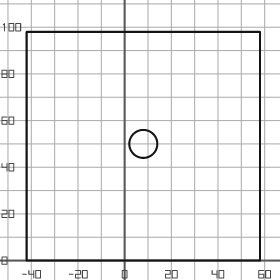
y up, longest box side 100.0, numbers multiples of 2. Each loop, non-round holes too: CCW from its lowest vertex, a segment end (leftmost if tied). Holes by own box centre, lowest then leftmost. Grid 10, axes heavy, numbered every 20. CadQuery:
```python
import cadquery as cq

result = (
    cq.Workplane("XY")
    .moveTo(-42.0, 0.0)
    .lineTo(58.0, 0.0)
    .lineTo(58.0, 98.0)
    .lineTo(-42.0, 98.0)
    .close()
    .moveTo(8.0, 50.0)
    .circle(6.0)
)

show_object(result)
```